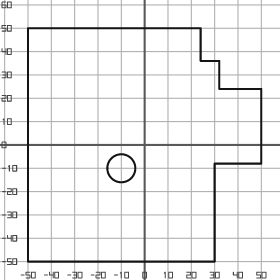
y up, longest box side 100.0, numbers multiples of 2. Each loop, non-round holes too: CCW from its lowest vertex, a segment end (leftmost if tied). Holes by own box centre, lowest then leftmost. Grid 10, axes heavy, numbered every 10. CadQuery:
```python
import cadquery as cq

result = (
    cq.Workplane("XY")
    .moveTo(-50.0, -50.0)
    .lineTo(30.0, -50.0)
    .lineTo(30.0, -8.0)
    .lineTo(50.0, -8.0)
    .lineTo(50.0, 24.0)
    .lineTo(32.0, 24.0)
    .lineTo(32.0, 36.0)
    .lineTo(24.0, 36.0)
    .lineTo(24.0, 50.0)
    .lineTo(-50.0, 50.0)
    .close()
    .moveTo(-10.0, -10.0)
    .circle(6.0)
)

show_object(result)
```